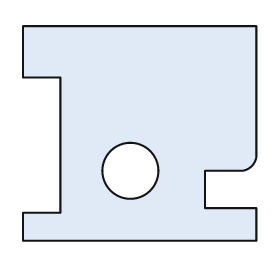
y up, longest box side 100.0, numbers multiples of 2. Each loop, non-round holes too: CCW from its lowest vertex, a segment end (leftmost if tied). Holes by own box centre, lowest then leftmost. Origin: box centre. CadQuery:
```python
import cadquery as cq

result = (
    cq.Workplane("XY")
    .moveTo(-50.0, -46.0)
    .lineTo(50.0, -46.0)
    .lineTo(50.0, -32.0)
    .lineTo(28.0, -32.0)
    .lineTo(28.0, -16.0)
    .lineTo(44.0, -16.0)
    .threePointArc((48.0, -14.0), (50.0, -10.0))
    .lineTo(50.0, 46.0)
    .lineTo(-50.0, 46.0)
    .lineTo(-50.0, 24.0)
    .lineTo(-34.0, 24.0)
    .lineTo(-34.0, -34.0)
    .lineTo(-50.0, -34.0)
    .close()
    .moveTo(-4.0, -16.0)
    .circle(12.0)
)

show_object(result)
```